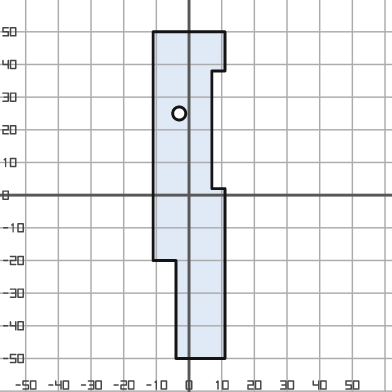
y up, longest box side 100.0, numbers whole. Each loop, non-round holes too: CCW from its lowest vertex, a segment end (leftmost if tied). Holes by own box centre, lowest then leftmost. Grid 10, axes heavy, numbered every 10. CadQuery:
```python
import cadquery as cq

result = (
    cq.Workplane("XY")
    .moveTo(-4.0, -50.0)
    .lineTo(11.0, -50.0)
    .lineTo(11.0, 2.0)
    .lineTo(7.0, 2.0)
    .lineTo(7.0, 38.0)
    .lineTo(11.0, 38.0)
    .lineTo(11.0, 50.0)
    .lineTo(-11.0, 50.0)
    .lineTo(-11.0, -20.0)
    .lineTo(-4.0, -20.0)
    .close()
    .moveTo(-3.0, 25.0)
    .circle(2.0)
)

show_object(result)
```